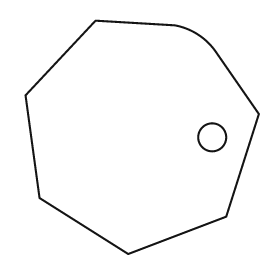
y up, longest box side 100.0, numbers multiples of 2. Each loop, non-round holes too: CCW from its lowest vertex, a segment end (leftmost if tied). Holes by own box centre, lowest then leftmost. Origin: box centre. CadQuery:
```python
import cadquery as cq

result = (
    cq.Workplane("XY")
    .moveTo(-6.0, -50.0)
    .lineTo(36.0, -34.0)
    .lineTo(50.0, 10.0)
    .lineTo(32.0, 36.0)
    .threePointArc((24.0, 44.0), (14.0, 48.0))
    .lineTo(-20.0, 50.0)
    .lineTo(-50.0, 18.0)
    .lineTo(-44.0, -26.0)
    .close()
    .moveTo(30.0, 0.0)
    .circle(6.0)
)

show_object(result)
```